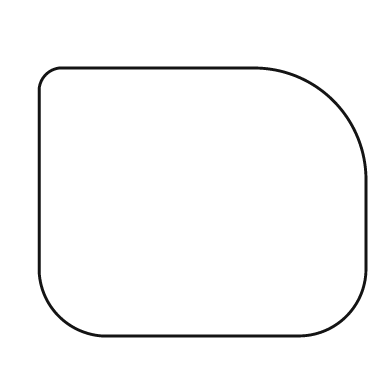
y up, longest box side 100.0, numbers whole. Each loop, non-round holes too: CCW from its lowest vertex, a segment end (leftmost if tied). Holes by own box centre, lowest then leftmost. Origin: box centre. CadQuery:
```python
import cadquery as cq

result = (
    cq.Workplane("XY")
    .moveTo(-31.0, -41.0)
    .lineTo(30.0, -41.0)
    .threePointArc((44.0, -35.0), (50.0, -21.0))
    .lineTo(50.0, 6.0)
    .threePointArc((40.0, 31.0), (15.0, 41.0))
    .lineTo(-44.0, 41.0)
    .threePointArc((-48.0, 39.0), (-50.0, 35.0))
    .lineTo(-50.0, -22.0)
    .threePointArc((-44.0, -35.0), (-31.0, -41.0))
    .close()
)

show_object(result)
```